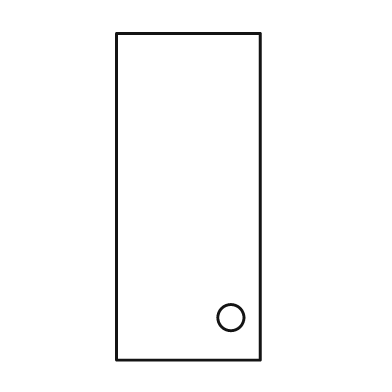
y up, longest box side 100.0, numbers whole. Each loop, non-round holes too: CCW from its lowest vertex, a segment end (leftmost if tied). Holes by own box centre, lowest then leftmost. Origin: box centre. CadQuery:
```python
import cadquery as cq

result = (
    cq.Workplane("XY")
    .moveTo(-22.0, -50.0)
    .lineTo(22.0, -50.0)
    .lineTo(22.0, 50.0)
    .lineTo(-22.0, 50.0)
    .close()
    .moveTo(13.0, -37.0)
    .circle(4.0)
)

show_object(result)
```